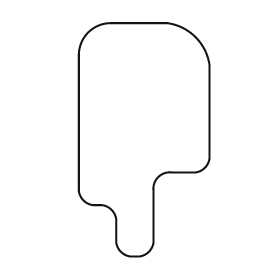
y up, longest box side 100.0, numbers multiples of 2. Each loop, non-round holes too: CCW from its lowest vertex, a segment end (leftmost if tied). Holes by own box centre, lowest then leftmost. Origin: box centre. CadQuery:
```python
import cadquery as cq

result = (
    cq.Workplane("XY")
    .moveTo(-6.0, -50.0)
    .lineTo(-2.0, -50.0)
    .threePointArc((2.0, -48.0), (4.0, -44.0))
    .lineTo(4.0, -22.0)
    .threePointArc((6.0, -16.0), (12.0, -14.0))
    .lineTo(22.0, -14.0)
    .threePointArc((26.0, -12.0), (28.0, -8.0))
    .lineTo(28.0, 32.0)
    .threePointArc((22.0, 44.0), (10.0, 50.0))
    .lineTo(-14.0, 50.0)
    .threePointArc((-24.0, 46.0), (-28.0, 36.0))
    .lineTo(-28.0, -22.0)
    .threePointArc((-26.0, -26.0), (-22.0, -28.0))
    .lineTo(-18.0, -28.0)
    .threePointArc((-14.0, -30.0), (-12.0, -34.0))
    .lineTo(-12.0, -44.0)
    .threePointArc((-10.0, -48.0), (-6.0, -50.0))
    .close()
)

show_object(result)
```